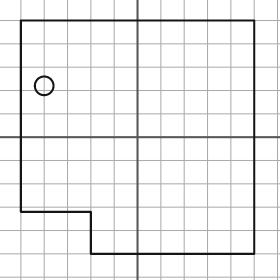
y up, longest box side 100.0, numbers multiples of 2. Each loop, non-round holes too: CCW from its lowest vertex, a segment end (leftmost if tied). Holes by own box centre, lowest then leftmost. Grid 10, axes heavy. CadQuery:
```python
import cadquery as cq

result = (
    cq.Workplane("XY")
    .moveTo(-20.0, -50.0)
    .lineTo(50.0, -50.0)
    .lineTo(50.0, 50.0)
    .lineTo(-50.0, 50.0)
    .lineTo(-50.0, -32.0)
    .lineTo(-20.0, -32.0)
    .close()
    .moveTo(-40.0, 22.0)
    .circle(4.0)
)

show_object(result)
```